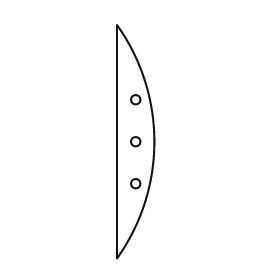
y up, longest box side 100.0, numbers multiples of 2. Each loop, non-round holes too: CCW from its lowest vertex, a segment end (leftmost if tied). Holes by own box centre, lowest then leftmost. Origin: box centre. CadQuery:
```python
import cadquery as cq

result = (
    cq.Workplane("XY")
    .moveTo(-8.0, -50.0)
    .threePointArc((8.0, 0.0), (-8.0, 50.0))
    .close()
    .moveTo(0.0, -18.0)
    .circle(2.0)
    .moveTo(0.0, 0.0)
    .circle(2.0)
    .moveTo(0.0, 18.0)
    .circle(2.0)
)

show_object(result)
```